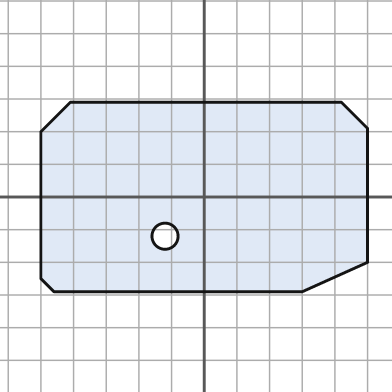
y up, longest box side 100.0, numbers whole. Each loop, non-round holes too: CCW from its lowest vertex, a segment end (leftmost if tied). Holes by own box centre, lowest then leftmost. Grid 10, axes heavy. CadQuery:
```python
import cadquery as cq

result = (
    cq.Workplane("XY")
    .moveTo(-46.0, -29.0)
    .lineTo(30.0, -29.0)
    .lineTo(50.0, -20.0)
    .lineTo(50.0, 21.0)
    .lineTo(42.0, 29.0)
    .lineTo(-41.0, 29.0)
    .lineTo(-50.0, 20.0)
    .lineTo(-50.0, -25.0)
    .close()
    .moveTo(-12.0, -12.0)
    .circle(4.0)
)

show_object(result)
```